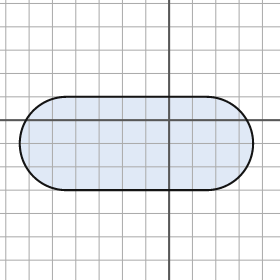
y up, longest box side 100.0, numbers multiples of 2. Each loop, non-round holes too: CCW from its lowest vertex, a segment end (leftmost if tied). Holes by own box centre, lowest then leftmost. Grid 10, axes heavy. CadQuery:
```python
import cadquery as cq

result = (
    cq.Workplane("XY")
    .moveTo(-44.0, -30.0)
    .lineTo(16.0, -30.0)
    .threePointArc((36.0, -10.0), (16.0, 10.0))
    .lineTo(-44.0, 10.0)
    .threePointArc((-64.0, -10.0), (-44.0, -30.0))
    .close()
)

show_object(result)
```